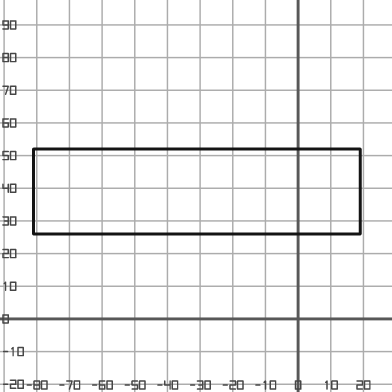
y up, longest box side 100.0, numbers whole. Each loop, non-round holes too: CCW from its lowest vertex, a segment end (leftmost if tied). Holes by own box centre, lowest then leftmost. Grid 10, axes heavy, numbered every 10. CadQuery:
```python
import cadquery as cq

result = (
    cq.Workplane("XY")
    .moveTo(-81.0, 26.0)
    .lineTo(19.0, 26.0)
    .lineTo(19.0, 52.0)
    .lineTo(-81.0, 52.0)
    .close()
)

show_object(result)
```